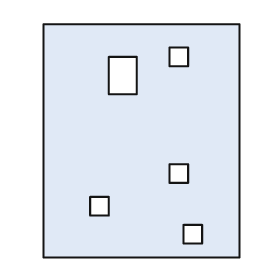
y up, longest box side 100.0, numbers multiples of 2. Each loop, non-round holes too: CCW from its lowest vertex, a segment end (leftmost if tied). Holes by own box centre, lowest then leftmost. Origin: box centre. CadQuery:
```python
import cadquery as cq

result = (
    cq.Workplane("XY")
    .moveTo(-42.0, -50.0)
    .lineTo(42.0, -50.0)
    .lineTo(42.0, 50.0)
    .lineTo(-42.0, 50.0)
    .close()
    .moveTo(18.0, -44.0)
    .lineTo(26.0, -44.0)
    .lineTo(26.0, -36.0)
    .lineTo(18.0, -36.0)
    .close()
    .moveTo(-22.0, -32.0)
    .lineTo(-14.0, -32.0)
    .lineTo(-14.0, -24.0)
    .lineTo(-22.0, -24.0)
    .close()
    .moveTo(12.0, -18.0)
    .lineTo(20.0, -18.0)
    .lineTo(20.0, -10.0)
    .lineTo(12.0, -10.0)
    .close()
    .moveTo(-14.0, 20.0)
    .lineTo(-2.0, 20.0)
    .lineTo(-2.0, 36.0)
    .lineTo(-14.0, 36.0)
    .close()
    .moveTo(12.0, 32.0)
    .lineTo(20.0, 32.0)
    .lineTo(20.0, 40.0)
    .lineTo(12.0, 40.0)
    .close()
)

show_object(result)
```